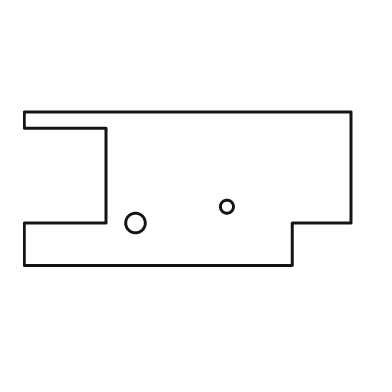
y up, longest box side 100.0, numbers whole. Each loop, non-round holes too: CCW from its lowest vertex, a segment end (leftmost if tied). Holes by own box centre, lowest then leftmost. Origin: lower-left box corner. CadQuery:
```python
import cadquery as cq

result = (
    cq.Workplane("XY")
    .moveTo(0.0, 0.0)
    .lineTo(82.0, 0.0)
    .lineTo(82.0, 13.0)
    .lineTo(100.0, 13.0)
    .lineTo(100.0, 47.0)
    .lineTo(0.0, 47.0)
    .lineTo(0.0, 42.0)
    .lineTo(25.0, 42.0)
    .lineTo(25.0, 13.0)
    .lineTo(0.0, 13.0)
    .close()
    .moveTo(34.0, 13.0)
    .circle(3.0)
    .moveTo(62.0, 18.0)
    .circle(2.0)
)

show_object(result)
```